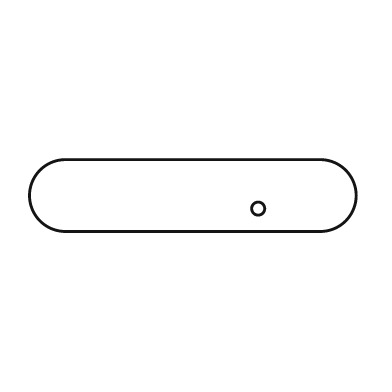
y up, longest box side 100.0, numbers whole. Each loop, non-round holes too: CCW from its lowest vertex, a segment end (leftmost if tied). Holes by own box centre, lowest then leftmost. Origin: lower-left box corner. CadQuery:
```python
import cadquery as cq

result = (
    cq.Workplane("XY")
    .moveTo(11.0, 0.0)
    .lineTo(89.0, 0.0)
    .threePointArc((100.0, 11.0), (89.0, 22.0))
    .lineTo(11.0, 22.0)
    .threePointArc((0.0, 11.0), (11.0, 0.0))
    .close()
    .moveTo(70.0, 7.0)
    .circle(2.0)
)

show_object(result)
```